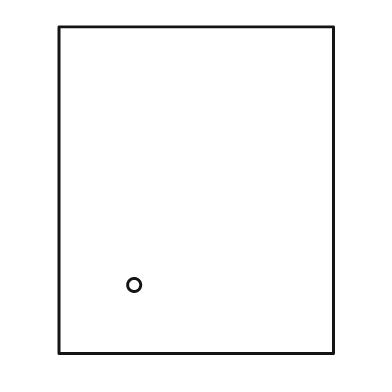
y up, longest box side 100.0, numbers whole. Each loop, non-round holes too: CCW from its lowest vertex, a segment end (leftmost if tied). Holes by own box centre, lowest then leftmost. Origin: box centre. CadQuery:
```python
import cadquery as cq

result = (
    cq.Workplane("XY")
    .moveTo(-42.0, -50.0)
    .lineTo(42.0, -50.0)
    .lineTo(42.0, 50.0)
    .lineTo(-42.0, 50.0)
    .close()
    .moveTo(-19.0, -29.0)
    .circle(2.0)
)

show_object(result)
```